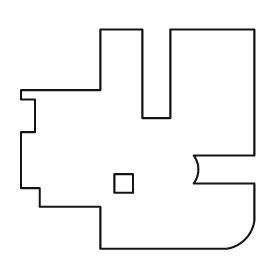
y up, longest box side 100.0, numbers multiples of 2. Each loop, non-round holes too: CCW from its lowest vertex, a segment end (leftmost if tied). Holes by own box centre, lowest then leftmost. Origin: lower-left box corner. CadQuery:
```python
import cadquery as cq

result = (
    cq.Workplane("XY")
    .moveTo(34.0, 0.0)
    .lineTo(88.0, 0.0)
    .threePointArc((96.0, 4.0), (100.0, 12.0))
    .lineTo(100.0, 28.0)
    .lineTo(74.0, 28.0)
    .threePointArc((76.0, 34.0), (74.0, 40.0))
    .lineTo(100.0, 40.0)
    .lineTo(100.0, 94.0)
    .lineTo(64.0, 94.0)
    .lineTo(64.0, 56.0)
    .lineTo(52.0, 56.0)
    .lineTo(52.0, 94.0)
    .lineTo(34.0, 94.0)
    .lineTo(34.0, 68.0)
    .lineTo(0.0, 68.0)
    .lineTo(0.0, 64.0)
    .lineTo(6.0, 64.0)
    .lineTo(6.0, 50.0)
    .lineTo(0.0, 50.0)
    .lineTo(0.0, 26.0)
    .lineTo(8.0, 26.0)
    .lineTo(8.0, 18.0)
    .lineTo(34.0, 18.0)
    .close()
    .moveTo(40.0, 24.0)
    .lineTo(48.0, 24.0)
    .lineTo(48.0, 32.0)
    .lineTo(40.0, 32.0)
    .close()
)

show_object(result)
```